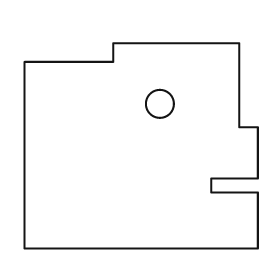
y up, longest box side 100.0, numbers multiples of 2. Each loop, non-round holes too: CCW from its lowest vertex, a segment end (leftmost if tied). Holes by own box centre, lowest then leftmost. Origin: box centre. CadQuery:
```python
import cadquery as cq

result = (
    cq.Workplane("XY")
    .moveTo(-50.0, -44.0)
    .lineTo(50.0, -44.0)
    .lineTo(50.0, -20.0)
    .lineTo(30.0, -20.0)
    .lineTo(30.0, -14.0)
    .lineTo(50.0, -14.0)
    .lineTo(50.0, 8.0)
    .lineTo(42.0, 8.0)
    .lineTo(42.0, 44.0)
    .lineTo(-12.0, 44.0)
    .lineTo(-12.0, 36.0)
    .lineTo(-50.0, 36.0)
    .close()
    .moveTo(8.0, 18.0)
    .circle(6.0)
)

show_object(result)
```